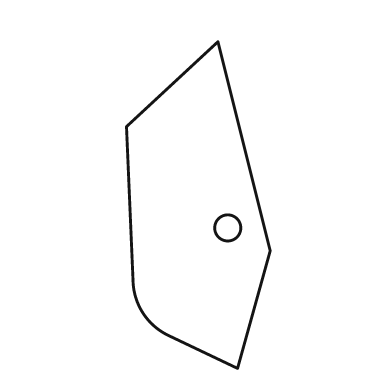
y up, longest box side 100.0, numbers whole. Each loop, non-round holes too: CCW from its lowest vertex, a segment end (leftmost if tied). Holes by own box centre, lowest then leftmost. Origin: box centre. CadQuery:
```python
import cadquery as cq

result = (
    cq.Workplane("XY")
    .moveTo(12.0, -50.0)
    .lineTo(22.0, -14.0)
    .lineTo(6.0, 50.0)
    .lineTo(-22.0, 24.0)
    .lineTo(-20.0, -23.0)
    .threePointArc((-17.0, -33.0), (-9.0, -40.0))
    .close()
    .moveTo(9.0, -7.0)
    .circle(4.0)
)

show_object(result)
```